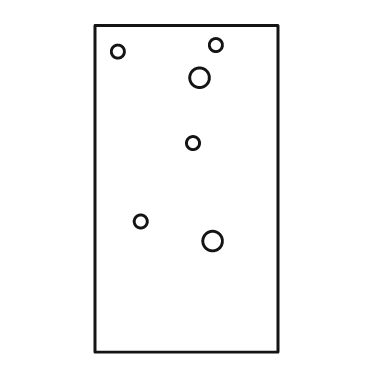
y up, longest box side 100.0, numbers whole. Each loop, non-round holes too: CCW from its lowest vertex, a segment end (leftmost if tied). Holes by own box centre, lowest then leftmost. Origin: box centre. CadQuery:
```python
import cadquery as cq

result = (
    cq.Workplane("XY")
    .moveTo(-28.0, -50.0)
    .lineTo(28.0, -50.0)
    .lineTo(28.0, 50.0)
    .lineTo(-28.0, 50.0)
    .close()
    .moveTo(8.0, -16.0)
    .circle(3.0)
    .moveTo(-14.0, -10.0)
    .circle(2.0)
    .moveTo(2.0, 14.0)
    .circle(2.0)
    .moveTo(4.0, 34.0)
    .circle(3.0)
    .moveTo(-21.0, 42.0)
    .circle(2.0)
    .moveTo(9.0, 44.0)
    .circle(2.0)
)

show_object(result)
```